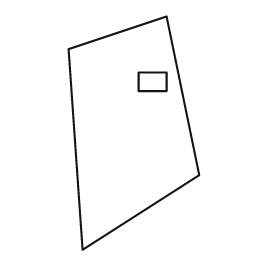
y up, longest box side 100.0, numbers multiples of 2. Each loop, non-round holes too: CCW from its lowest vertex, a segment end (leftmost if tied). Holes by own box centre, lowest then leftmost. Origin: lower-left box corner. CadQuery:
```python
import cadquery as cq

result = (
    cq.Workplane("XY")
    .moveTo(6.0, 0.0)
    .lineTo(56.0, 32.0)
    .lineTo(42.0, 100.0)
    .lineTo(0.0, 86.0)
    .close()
    .moveTo(30.0, 68.0)
    .lineTo(42.0, 68.0)
    .lineTo(42.0, 76.0)
    .lineTo(30.0, 76.0)
    .close()
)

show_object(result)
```